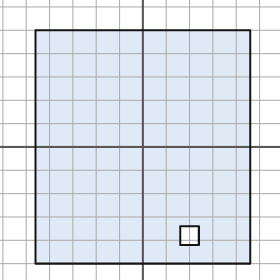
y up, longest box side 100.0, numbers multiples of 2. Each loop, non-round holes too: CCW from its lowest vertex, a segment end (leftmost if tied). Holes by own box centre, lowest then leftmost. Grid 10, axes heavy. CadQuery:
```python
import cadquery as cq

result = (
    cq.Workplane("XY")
    .moveTo(-46.0, -50.0)
    .lineTo(46.0, -50.0)
    .lineTo(46.0, 50.0)
    .lineTo(-46.0, 50.0)
    .close()
    .moveTo(16.0, -42.0)
    .lineTo(24.0, -42.0)
    .lineTo(24.0, -34.0)
    .lineTo(16.0, -34.0)
    .close()
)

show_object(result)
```